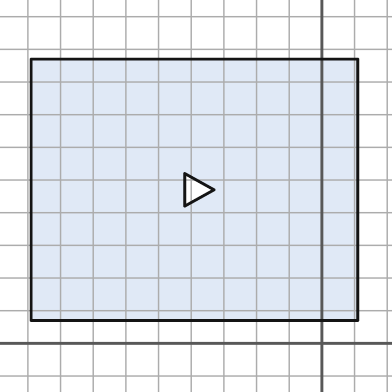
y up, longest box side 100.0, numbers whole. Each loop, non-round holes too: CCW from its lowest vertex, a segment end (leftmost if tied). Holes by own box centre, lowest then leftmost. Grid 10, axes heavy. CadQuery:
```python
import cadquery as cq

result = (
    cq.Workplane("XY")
    .moveTo(-89.0, 7.0)
    .lineTo(11.0, 7.0)
    .lineTo(11.0, 87.0)
    .lineTo(-89.0, 87.0)
    .close()
    .moveTo(-42.0, 42.0)
    .lineTo(-33.0, 47.0)
    .lineTo(-42.0, 52.0)
    .close()
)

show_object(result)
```